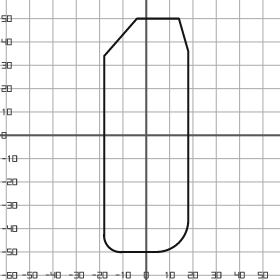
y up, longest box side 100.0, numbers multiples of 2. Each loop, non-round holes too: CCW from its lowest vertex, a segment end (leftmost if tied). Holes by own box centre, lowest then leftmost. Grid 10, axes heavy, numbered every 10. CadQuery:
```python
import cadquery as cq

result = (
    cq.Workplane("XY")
    .moveTo(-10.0, -50.0)
    .lineTo(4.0, -50.0)
    .threePointArc((14.0, -46.0), (18.0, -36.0))
    .lineTo(18.0, 36.0)
    .lineTo(14.0, 50.0)
    .lineTo(-4.0, 50.0)
    .lineTo(-18.0, 34.0)
    .lineTo(-18.0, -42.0)
    .threePointArc((-16.0, -48.0), (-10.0, -50.0))
    .close()
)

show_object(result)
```